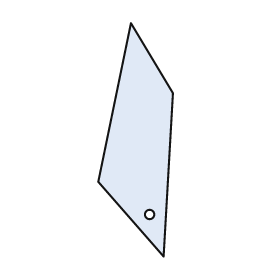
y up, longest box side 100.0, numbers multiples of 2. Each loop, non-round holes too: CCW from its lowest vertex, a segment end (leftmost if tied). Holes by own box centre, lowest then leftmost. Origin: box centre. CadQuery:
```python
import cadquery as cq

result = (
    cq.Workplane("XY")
    .moveTo(12.0, -50.0)
    .lineTo(16.0, 20.0)
    .lineTo(-2.0, 50.0)
    .lineTo(-16.0, -18.0)
    .close()
    .moveTo(6.0, -32.0)
    .circle(2.0)
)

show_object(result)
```